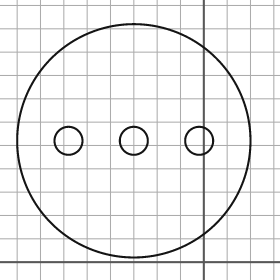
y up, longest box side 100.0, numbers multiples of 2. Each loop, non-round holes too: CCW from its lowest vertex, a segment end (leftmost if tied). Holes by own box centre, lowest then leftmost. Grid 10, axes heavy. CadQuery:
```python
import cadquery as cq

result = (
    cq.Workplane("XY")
    .moveTo(-30.0, 52.0)
    .circle(50.0)
    .moveTo(-58.0, 52.0)
    .circle(6.0)
    .moveTo(-30.0, 52.0)
    .circle(6.0)
    .moveTo(-2.0, 52.0)
    .circle(6.0)
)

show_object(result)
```